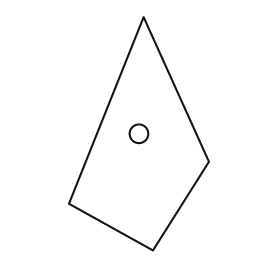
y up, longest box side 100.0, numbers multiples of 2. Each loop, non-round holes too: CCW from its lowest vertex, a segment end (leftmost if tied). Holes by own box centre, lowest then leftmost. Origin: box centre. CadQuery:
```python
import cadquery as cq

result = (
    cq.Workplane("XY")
    .moveTo(6.0, -50.0)
    .lineTo(30.0, -12.0)
    .lineTo(2.0, 50.0)
    .lineTo(-30.0, -30.0)
    .close()
    .moveTo(0.0, 0.0)
    .circle(4.0)
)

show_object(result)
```